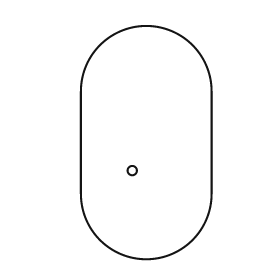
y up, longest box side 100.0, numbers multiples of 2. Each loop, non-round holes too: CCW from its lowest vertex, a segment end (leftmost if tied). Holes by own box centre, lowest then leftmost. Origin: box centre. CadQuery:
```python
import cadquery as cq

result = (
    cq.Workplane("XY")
    .moveTo(-28.0, -22.0)
    .threePointArc((0.0, -50.0), (28.0, -22.0))
    .lineTo(28.0, 22.0)
    .threePointArc((0.0, 50.0), (-28.0, 22.0))
    .close()
    .moveTo(-6.0, -12.0)
    .circle(2.0)
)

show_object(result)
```